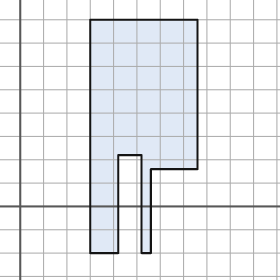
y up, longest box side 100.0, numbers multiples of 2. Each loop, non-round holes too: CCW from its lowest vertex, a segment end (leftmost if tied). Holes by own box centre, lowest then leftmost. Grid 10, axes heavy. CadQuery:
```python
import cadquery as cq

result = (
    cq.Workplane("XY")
    .moveTo(30.0, -20.0)
    .lineTo(42.0, -20.0)
    .lineTo(42.0, 22.0)
    .lineTo(52.0, 22.0)
    .lineTo(52.0, -20.0)
    .lineTo(56.0, -20.0)
    .lineTo(56.0, 16.0)
    .lineTo(76.0, 16.0)
    .lineTo(76.0, 80.0)
    .lineTo(30.0, 80.0)
    .close()
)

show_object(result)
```